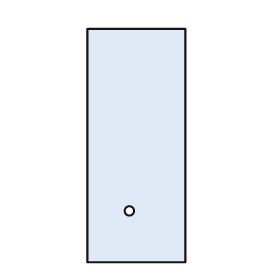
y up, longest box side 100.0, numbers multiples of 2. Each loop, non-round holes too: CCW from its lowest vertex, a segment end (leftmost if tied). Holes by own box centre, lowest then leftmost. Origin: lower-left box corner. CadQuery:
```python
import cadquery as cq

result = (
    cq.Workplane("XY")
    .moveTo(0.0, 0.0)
    .lineTo(42.0, 0.0)
    .lineTo(42.0, 100.0)
    .lineTo(0.0, 100.0)
    .close()
    .moveTo(18.0, 22.0)
    .circle(2.0)
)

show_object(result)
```